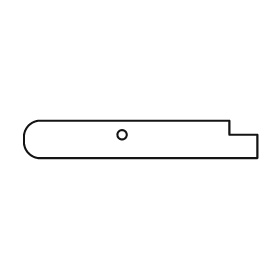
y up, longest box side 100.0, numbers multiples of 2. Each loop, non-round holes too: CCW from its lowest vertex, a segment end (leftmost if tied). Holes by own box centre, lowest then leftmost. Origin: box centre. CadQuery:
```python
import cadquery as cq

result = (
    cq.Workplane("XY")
    .moveTo(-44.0, -8.0)
    .lineTo(50.0, -8.0)
    .lineTo(50.0, 2.0)
    .lineTo(38.0, 2.0)
    .lineTo(38.0, 8.0)
    .lineTo(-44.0, 8.0)
    .threePointArc((-48.0, 6.0), (-50.0, 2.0))
    .lineTo(-50.0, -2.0)
    .threePointArc((-48.0, -6.0), (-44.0, -8.0))
    .close()
    .moveTo(-8.0, 2.0)
    .circle(2.0)
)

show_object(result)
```